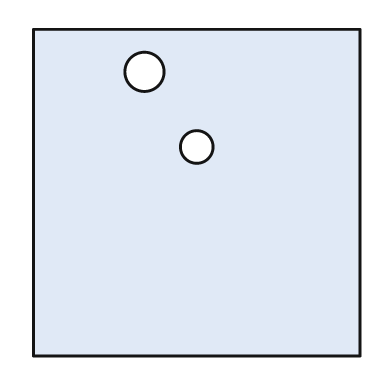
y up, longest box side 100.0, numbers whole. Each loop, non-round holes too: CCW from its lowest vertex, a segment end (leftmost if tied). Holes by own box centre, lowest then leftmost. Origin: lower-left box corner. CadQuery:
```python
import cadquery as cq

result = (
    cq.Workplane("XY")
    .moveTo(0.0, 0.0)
    .lineTo(100.0, 0.0)
    .lineTo(100.0, 100.0)
    .lineTo(0.0, 100.0)
    .close()
    .moveTo(50.0, 64.0)
    .circle(5.0)
    .moveTo(34.0, 87.0)
    .circle(6.0)
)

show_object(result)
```